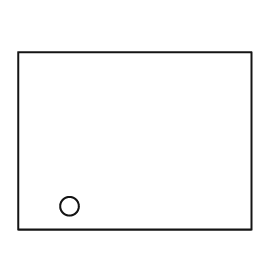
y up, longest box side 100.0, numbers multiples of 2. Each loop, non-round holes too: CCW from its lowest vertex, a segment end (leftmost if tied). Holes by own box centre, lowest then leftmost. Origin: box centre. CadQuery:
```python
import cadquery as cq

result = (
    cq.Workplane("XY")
    .moveTo(-50.0, -38.0)
    .lineTo(50.0, -38.0)
    .lineTo(50.0, 38.0)
    .lineTo(-50.0, 38.0)
    .close()
    .moveTo(-28.0, -28.0)
    .circle(4.0)
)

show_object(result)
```